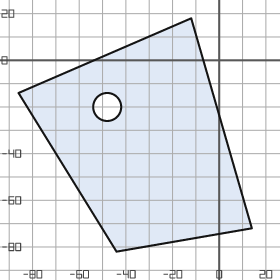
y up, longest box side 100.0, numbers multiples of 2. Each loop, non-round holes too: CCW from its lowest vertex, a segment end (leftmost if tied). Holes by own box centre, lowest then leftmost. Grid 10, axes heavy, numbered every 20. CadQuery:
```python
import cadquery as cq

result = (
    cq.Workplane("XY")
    .moveTo(-44.0, -82.0)
    .lineTo(14.0, -72.0)
    .lineTo(-12.0, 18.0)
    .lineTo(-86.0, -14.0)
    .close()
    .moveTo(-48.0, -20.0)
    .circle(6.0)
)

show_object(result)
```